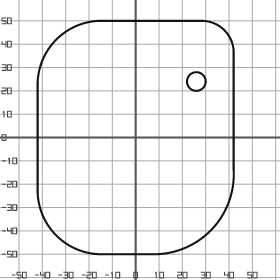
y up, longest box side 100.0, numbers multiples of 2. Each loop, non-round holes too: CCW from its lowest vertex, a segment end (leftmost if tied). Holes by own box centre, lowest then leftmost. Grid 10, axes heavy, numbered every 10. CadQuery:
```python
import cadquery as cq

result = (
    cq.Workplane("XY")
    .moveTo(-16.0, -50.0)
    .lineTo(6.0, -50.0)
    .threePointArc((32.0, -40.0), (42.0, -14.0))
    .lineTo(42.0, 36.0)
    .threePointArc((38.0, 46.0), (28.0, 50.0))
    .lineTo(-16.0, 50.0)
    .threePointArc((-34.0, 42.0), (-42.0, 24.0))
    .lineTo(-42.0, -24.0)
    .threePointArc((-34.0, -42.0), (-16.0, -50.0))
    .close()
    .moveTo(26.0, 24.0)
    .circle(4.0)
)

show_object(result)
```